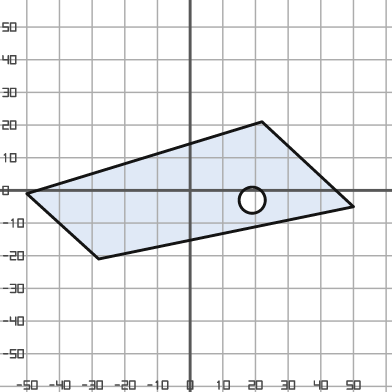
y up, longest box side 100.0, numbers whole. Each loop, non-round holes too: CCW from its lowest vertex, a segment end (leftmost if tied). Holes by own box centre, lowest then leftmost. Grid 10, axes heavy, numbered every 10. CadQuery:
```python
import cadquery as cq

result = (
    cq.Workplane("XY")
    .moveTo(-28.0, -21.0)
    .lineTo(50.0, -5.0)
    .lineTo(22.0, 21.0)
    .lineTo(-50.0, -1.0)
    .close()
    .moveTo(19.0, -3.0)
    .circle(4.0)
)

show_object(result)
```